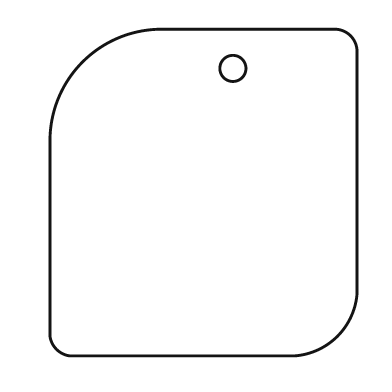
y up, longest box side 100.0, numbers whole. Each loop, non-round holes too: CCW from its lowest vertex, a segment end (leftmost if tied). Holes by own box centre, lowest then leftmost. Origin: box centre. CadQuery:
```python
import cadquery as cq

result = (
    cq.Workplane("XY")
    .moveTo(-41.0, -50.0)
    .lineTo(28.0, -50.0)
    .threePointArc((41.0, -44.0), (47.0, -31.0))
    .lineTo(47.0, 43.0)
    .threePointArc((45.0, 48.0), (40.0, 50.0))
    .lineTo(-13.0, 50.0)
    .threePointArc((-37.0, 40.0), (-47.0, 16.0))
    .lineTo(-47.0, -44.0)
    .threePointArc((-45.0, -48.0), (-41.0, -50.0))
    .close()
    .moveTo(9.0, 38.0)
    .circle(4.0)
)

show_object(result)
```